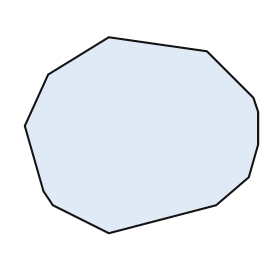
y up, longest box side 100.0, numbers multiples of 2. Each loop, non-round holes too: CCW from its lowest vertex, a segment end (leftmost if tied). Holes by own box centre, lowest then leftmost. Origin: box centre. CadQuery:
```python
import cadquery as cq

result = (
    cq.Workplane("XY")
    .moveTo(-14.0, -42.0)
    .lineTo(32.0, -30.0)
    .lineTo(46.0, -18.0)
    .lineTo(50.0, -4.0)
    .lineTo(50.0, 10.0)
    .lineTo(48.0, 16.0)
    .lineTo(28.0, 36.0)
    .lineTo(-14.0, 42.0)
    .lineTo(-40.0, 26.0)
    .lineTo(-50.0, 4.0)
    .lineTo(-42.0, -24.0)
    .lineTo(-38.0, -30.0)
    .close()
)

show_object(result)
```